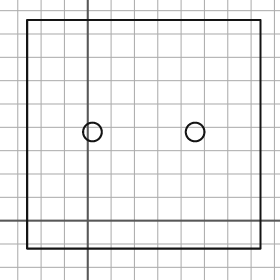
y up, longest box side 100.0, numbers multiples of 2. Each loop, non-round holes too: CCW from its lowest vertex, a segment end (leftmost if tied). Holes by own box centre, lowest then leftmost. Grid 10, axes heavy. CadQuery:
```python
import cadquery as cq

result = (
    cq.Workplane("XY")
    .moveTo(-26.0, -12.0)
    .lineTo(74.0, -12.0)
    .lineTo(74.0, 86.0)
    .lineTo(-26.0, 86.0)
    .close()
    .moveTo(2.0, 38.0)
    .circle(4.0)
    .moveTo(46.0, 38.0)
    .circle(4.0)
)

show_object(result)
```